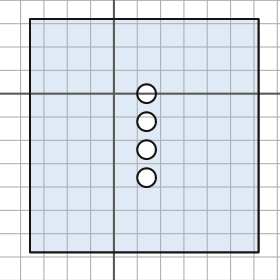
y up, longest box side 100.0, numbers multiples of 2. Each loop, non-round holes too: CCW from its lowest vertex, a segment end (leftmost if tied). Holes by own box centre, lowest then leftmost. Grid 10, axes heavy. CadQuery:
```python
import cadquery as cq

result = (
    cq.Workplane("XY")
    .moveTo(-36.0, -68.0)
    .lineTo(62.0, -68.0)
    .lineTo(62.0, 32.0)
    .lineTo(-36.0, 32.0)
    .close()
    .moveTo(14.0, -36.0)
    .circle(4.0)
    .moveTo(14.0, -24.0)
    .circle(4.0)
    .moveTo(14.0, -12.0)
    .circle(4.0)
    .moveTo(14.0, 0.0)
    .circle(4.0)
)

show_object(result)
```